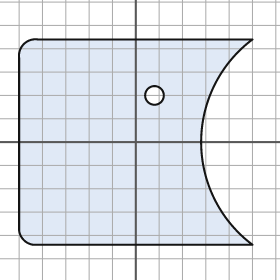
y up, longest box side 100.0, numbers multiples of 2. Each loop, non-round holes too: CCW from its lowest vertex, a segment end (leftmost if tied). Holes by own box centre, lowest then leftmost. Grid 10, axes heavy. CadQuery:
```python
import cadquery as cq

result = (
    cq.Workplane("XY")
    .moveTo(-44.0, -44.0)
    .lineTo(50.0, -44.0)
    .threePointArc((28.0, 0.0), (50.0, 44.0))
    .lineTo(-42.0, 44.0)
    .threePointArc((-48.0, 42.0), (-50.0, 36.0))
    .lineTo(-50.0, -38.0)
    .threePointArc((-48.0, -42.0), (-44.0, -44.0))
    .close()
    .moveTo(8.0, 20.0)
    .circle(4.0)
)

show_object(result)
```